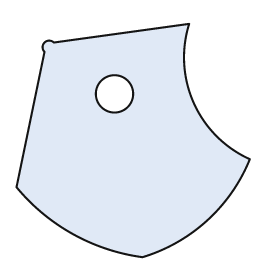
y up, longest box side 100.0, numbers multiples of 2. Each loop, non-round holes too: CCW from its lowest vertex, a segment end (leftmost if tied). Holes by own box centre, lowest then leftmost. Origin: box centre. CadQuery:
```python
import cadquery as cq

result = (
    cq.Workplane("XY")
    .moveTo(4.0, -50.0)
    .threePointArc((32.0, -34.0), (50.0, -8.0))
    .threePointArc((26.0, 16.0), (24.0, 50.0))
    .lineTo(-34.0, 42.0)
    .threePointArc((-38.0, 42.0), (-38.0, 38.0))
    .lineTo(-50.0, -20.0)
    .threePointArc((-26.0, -40.0), (4.0, -50.0))
    .close()
    .moveTo(-8.0, 20.0)
    .circle(8.0)
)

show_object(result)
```